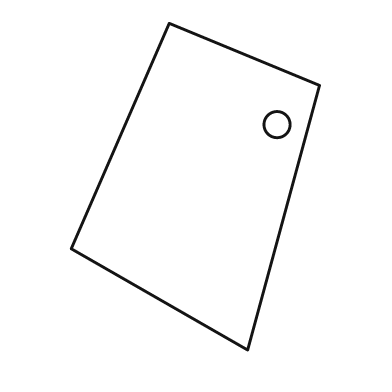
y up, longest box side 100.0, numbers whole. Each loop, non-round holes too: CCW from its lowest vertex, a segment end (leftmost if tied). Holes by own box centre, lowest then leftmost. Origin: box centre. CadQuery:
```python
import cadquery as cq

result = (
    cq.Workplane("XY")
    .moveTo(16.0, -50.0)
    .lineTo(38.0, 31.0)
    .lineTo(-8.0, 50.0)
    .lineTo(-38.0, -19.0)
    .close()
    .moveTo(25.0, 19.0)
    .circle(4.0)
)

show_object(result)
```